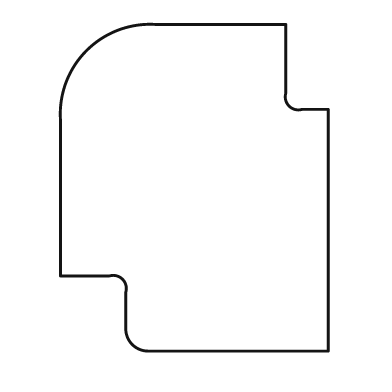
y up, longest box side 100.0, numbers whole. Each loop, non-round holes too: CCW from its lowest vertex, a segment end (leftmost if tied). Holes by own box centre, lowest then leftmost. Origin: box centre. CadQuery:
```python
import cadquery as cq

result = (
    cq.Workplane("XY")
    .moveTo(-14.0, -50.0)
    .lineTo(41.0, -50.0)
    .lineTo(41.0, 24.0)
    .lineTo(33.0, 24.0)
    .threePointArc((29.0, 25.0), (28.0, 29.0))
    .lineTo(28.0, 50.0)
    .lineTo(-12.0, 50.0)
    .threePointArc((-33.0, 42.0), (-41.0, 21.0))
    .lineTo(-41.0, -27.0)
    .lineTo(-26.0, -27.0)
    .threePointArc((-22.0, -28.0), (-21.0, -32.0))
    .lineTo(-21.0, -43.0)
    .threePointArc((-19.0, -48.0), (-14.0, -50.0))
    .close()
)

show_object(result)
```